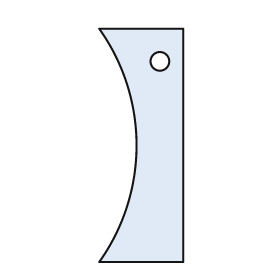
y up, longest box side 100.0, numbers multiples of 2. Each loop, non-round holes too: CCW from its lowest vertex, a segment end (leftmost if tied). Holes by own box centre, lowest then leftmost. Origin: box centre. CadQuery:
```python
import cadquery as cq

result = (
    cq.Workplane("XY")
    .moveTo(-18.0, -50.0)
    .lineTo(18.0, -50.0)
    .lineTo(18.0, 50.0)
    .lineTo(-18.0, 50.0)
    .threePointArc((-2.0, 0.0), (-18.0, -50.0))
    .close()
    .moveTo(8.0, 36.0)
    .circle(4.0)
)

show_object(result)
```